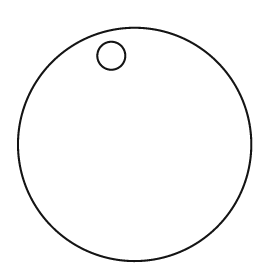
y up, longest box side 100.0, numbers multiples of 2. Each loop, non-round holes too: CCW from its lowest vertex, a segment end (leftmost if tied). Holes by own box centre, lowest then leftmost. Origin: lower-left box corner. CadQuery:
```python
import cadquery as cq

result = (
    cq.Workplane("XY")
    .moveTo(50.0, 50.0)
    .circle(50.0)
    .moveTo(40.0, 88.0)
    .circle(6.0)
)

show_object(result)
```